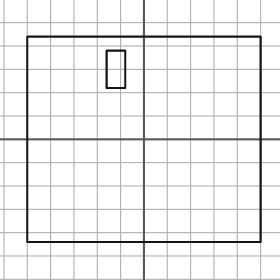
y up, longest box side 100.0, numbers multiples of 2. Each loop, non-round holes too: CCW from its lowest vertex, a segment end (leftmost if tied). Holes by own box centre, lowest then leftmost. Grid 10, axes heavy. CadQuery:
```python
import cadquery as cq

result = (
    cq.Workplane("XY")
    .moveTo(-50.0, -44.0)
    .lineTo(50.0, -44.0)
    .lineTo(50.0, 44.0)
    .lineTo(-50.0, 44.0)
    .close()
    .moveTo(-16.0, 22.0)
    .lineTo(-8.0, 22.0)
    .lineTo(-8.0, 38.0)
    .lineTo(-16.0, 38.0)
    .close()
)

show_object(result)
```